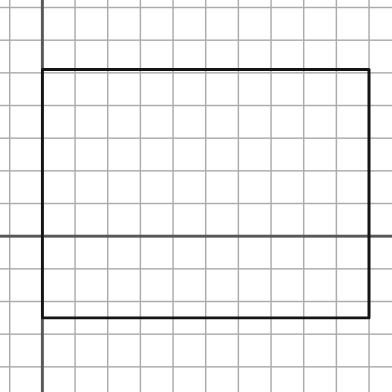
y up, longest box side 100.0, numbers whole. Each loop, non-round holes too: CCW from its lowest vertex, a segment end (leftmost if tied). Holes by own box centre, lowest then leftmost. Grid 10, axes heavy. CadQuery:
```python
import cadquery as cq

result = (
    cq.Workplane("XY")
    .moveTo(0.0, -25.0)
    .lineTo(100.0, -25.0)
    .lineTo(100.0, 51.0)
    .lineTo(0.0, 51.0)
    .close()
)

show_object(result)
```